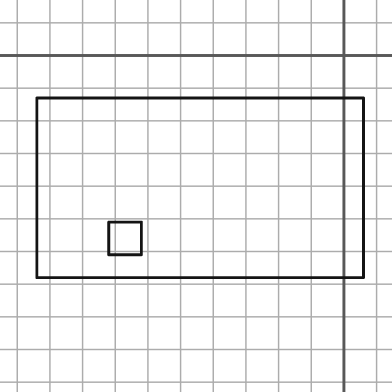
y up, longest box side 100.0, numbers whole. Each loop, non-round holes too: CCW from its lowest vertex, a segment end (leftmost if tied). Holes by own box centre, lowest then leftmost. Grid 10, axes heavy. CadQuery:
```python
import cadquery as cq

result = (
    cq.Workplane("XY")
    .moveTo(-94.0, -68.0)
    .lineTo(6.0, -68.0)
    .lineTo(6.0, -13.0)
    .lineTo(-94.0, -13.0)
    .close()
    .moveTo(-72.0, -61.0)
    .lineTo(-62.0, -61.0)
    .lineTo(-62.0, -51.0)
    .lineTo(-72.0, -51.0)
    .close()
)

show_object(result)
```